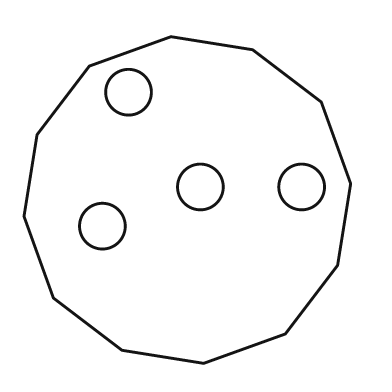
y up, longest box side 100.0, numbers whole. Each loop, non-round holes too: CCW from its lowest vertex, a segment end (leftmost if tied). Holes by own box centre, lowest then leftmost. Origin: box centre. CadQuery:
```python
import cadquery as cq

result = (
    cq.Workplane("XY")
    .moveTo(5.0, -50.0)
    .lineTo(30.0, -41.0)
    .lineTo(46.0, -20.0)
    .lineTo(50.0, 5.0)
    .lineTo(41.0, 30.0)
    .lineTo(20.0, 46.0)
    .lineTo(-5.0, 50.0)
    .lineTo(-30.0, 41.0)
    .lineTo(-46.0, 20.0)
    .lineTo(-50.0, -5.0)
    .lineTo(-41.0, -30.0)
    .lineTo(-20.0, -46.0)
    .close()
    .moveTo(-26.0, -8.0)
    .circle(7.0)
    .moveTo(4.0, 4.0)
    .circle(7.0)
    .moveTo(35.0, 4.0)
    .circle(7.0)
    .moveTo(-18.0, 33.0)
    .circle(7.0)
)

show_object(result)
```